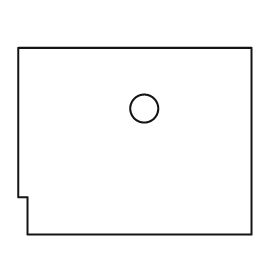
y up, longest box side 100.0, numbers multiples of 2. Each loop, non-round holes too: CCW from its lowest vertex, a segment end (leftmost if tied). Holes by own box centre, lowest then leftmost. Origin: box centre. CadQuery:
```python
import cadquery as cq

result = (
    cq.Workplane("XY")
    .moveTo(-46.0, -40.0)
    .lineTo(50.0, -40.0)
    .lineTo(50.0, 40.0)
    .lineTo(-50.0, 40.0)
    .lineTo(-50.0, -24.0)
    .lineTo(-46.0, -24.0)
    .close()
    .moveTo(4.0, 14.0)
    .circle(6.0)
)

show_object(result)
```